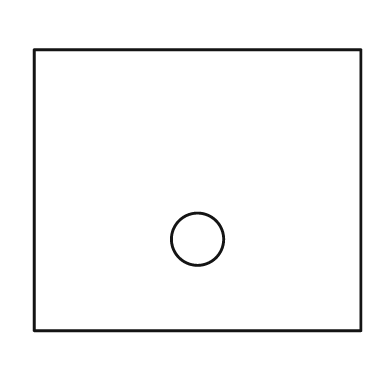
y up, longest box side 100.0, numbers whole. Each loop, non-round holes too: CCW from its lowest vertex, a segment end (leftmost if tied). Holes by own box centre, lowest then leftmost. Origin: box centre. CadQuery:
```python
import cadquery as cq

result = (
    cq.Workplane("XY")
    .moveTo(-50.0, -43.0)
    .lineTo(50.0, -43.0)
    .lineTo(50.0, 43.0)
    .lineTo(-50.0, 43.0)
    .close()
    .moveTo(0.0, -15.0)
    .circle(8.0)
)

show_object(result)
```